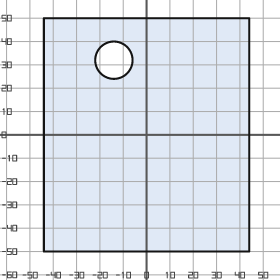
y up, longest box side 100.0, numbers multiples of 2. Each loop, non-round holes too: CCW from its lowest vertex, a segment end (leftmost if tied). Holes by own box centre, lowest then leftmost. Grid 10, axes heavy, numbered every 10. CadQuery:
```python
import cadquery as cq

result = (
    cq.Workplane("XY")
    .moveTo(-44.0, -50.0)
    .lineTo(44.0, -50.0)
    .lineTo(44.0, 50.0)
    .lineTo(-44.0, 50.0)
    .close()
    .moveTo(-14.0, 32.0)
    .circle(8.0)
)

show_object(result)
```